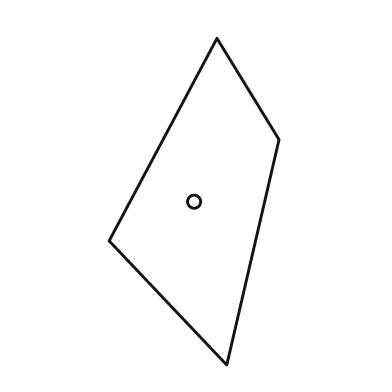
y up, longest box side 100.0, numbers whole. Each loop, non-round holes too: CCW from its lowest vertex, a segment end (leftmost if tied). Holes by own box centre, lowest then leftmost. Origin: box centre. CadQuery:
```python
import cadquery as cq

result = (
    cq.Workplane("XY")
    .moveTo(10.0, -50.0)
    .lineTo(26.0, 19.0)
    .lineTo(7.0, 50.0)
    .lineTo(-26.0, -12.0)
    .close()
    .moveTo(0.0, 0.0)
    .circle(2.0)
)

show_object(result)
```